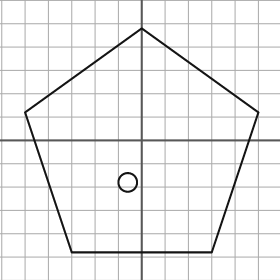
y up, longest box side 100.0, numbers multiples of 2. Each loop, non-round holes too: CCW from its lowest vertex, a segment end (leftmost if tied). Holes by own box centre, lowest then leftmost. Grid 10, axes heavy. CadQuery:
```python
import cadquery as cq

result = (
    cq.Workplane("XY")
    .moveTo(-30.0, -48.0)
    .lineTo(30.0, -48.0)
    .lineTo(50.0, 12.0)
    .lineTo(0.0, 48.0)
    .lineTo(-50.0, 12.0)
    .close()
    .moveTo(-6.0, -18.0)
    .circle(4.0)
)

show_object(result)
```